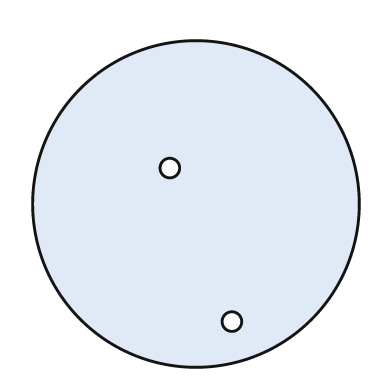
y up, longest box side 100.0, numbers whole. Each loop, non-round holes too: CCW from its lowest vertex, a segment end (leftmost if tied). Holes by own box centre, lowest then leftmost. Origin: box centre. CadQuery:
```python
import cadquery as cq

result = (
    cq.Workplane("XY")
    .moveTo(0.0, 0.0)
    .circle(50.0)
    .moveTo(11.0, -36.0)
    .circle(3.0)
    .moveTo(-8.0, 11.0)
    .circle(3.0)
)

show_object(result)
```